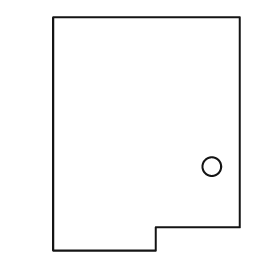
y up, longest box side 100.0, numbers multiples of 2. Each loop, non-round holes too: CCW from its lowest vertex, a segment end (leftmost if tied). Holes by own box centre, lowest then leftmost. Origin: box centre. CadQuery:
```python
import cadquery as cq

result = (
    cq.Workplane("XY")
    .moveTo(-40.0, -50.0)
    .lineTo(4.0, -50.0)
    .lineTo(4.0, -40.0)
    .lineTo(40.0, -40.0)
    .lineTo(40.0, 50.0)
    .lineTo(-40.0, 50.0)
    .close()
    .moveTo(28.0, -14.0)
    .circle(4.0)
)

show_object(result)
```